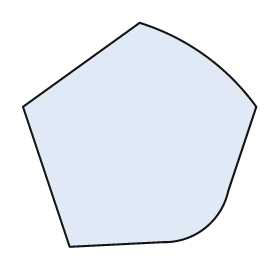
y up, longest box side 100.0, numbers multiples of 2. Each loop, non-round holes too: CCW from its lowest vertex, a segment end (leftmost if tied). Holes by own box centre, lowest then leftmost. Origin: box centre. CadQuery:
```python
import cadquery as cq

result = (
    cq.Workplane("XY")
    .moveTo(-30.0, -48.0)
    .lineTo(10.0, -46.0)
    .threePointArc((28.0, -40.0), (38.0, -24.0))
    .lineTo(50.0, 12.0)
    .threePointArc((28.0, 34.0), (0.0, 48.0))
    .lineTo(-50.0, 12.0)
    .close()
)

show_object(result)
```